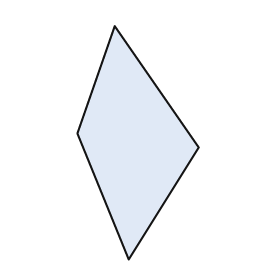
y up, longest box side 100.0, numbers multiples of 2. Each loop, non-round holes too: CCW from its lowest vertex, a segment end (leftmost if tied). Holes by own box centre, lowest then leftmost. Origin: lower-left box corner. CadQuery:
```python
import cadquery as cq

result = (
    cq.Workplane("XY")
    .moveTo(22.0, 0.0)
    .lineTo(52.0, 48.0)
    .lineTo(16.0, 100.0)
    .lineTo(0.0, 54.0)
    .close()
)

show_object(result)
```